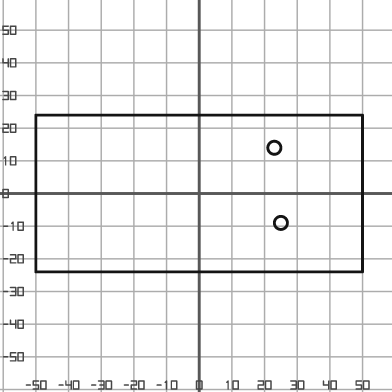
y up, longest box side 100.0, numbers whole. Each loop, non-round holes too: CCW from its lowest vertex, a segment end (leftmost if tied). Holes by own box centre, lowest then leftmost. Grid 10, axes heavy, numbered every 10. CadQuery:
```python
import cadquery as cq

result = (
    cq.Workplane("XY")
    .moveTo(-50.0, -24.0)
    .lineTo(50.0, -24.0)
    .lineTo(50.0, 24.0)
    .lineTo(-50.0, 24.0)
    .close()
    .moveTo(25.0, -9.0)
    .circle(2.0)
    .moveTo(23.0, 14.0)
    .circle(2.0)
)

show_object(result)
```